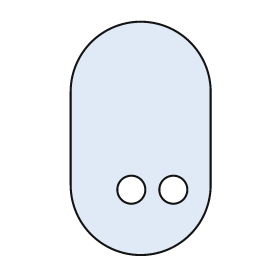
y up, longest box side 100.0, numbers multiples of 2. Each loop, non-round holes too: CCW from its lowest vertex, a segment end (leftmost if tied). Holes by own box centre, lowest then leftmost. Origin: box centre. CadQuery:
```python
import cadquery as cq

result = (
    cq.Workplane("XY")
    .moveTo(-30.0, -20.0)
    .threePointArc((0.0, -50.0), (30.0, -20.0))
    .lineTo(30.0, 20.0)
    .threePointArc((0.0, 50.0), (-30.0, 20.0))
    .close()
    .moveTo(-4.0, -22.0)
    .circle(6.0)
    .moveTo(14.0, -22.0)
    .circle(6.0)
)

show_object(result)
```